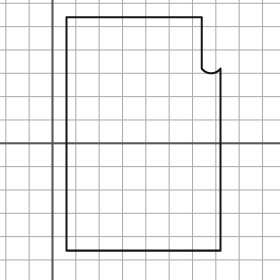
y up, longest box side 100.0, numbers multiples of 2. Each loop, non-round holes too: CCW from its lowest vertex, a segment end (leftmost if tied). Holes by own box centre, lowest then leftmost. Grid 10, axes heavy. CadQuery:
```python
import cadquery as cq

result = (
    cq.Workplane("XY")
    .moveTo(6.0, -46.0)
    .lineTo(72.0, -46.0)
    .lineTo(72.0, 32.0)
    .threePointArc((68.0, 30.0), (64.0, 32.0))
    .lineTo(64.0, 54.0)
    .lineTo(6.0, 54.0)
    .close()
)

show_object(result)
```